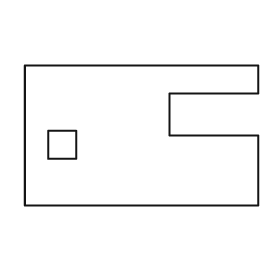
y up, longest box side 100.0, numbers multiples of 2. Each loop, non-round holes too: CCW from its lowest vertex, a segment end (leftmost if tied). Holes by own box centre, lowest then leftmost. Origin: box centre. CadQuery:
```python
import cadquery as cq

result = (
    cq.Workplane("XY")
    .moveTo(-50.0, -30.0)
    .lineTo(50.0, -30.0)
    .lineTo(50.0, 0.0)
    .lineTo(12.0, 0.0)
    .lineTo(12.0, 18.0)
    .lineTo(50.0, 18.0)
    .lineTo(50.0, 30.0)
    .lineTo(-50.0, 30.0)
    .close()
    .moveTo(-40.0, -10.0)
    .lineTo(-28.0, -10.0)
    .lineTo(-28.0, 2.0)
    .lineTo(-40.0, 2.0)
    .close()
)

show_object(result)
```